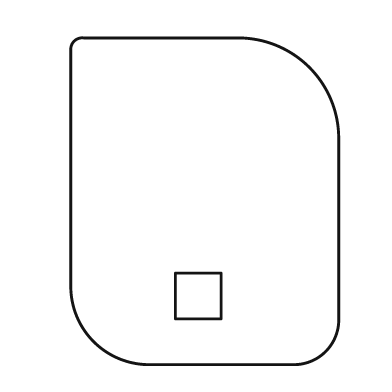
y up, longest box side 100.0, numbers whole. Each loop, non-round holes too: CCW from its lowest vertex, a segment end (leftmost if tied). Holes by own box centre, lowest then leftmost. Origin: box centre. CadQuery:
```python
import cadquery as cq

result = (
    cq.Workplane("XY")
    .moveTo(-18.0, -50.0)
    .lineTo(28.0, -50.0)
    .threePointArc((37.0, -46.0), (41.0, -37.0))
    .lineTo(41.0, 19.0)
    .threePointArc((32.0, 41.0), (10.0, 50.0))
    .lineTo(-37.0, 50.0)
    .threePointArc((-40.0, 49.0), (-41.0, 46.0))
    .lineTo(-41.0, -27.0)
    .threePointArc((-34.0, -43.0), (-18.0, -50.0))
    .close()
    .moveTo(-9.0, -36.0)
    .lineTo(5.0, -36.0)
    .lineTo(5.0, -22.0)
    .lineTo(-9.0, -22.0)
    .close()
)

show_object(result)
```